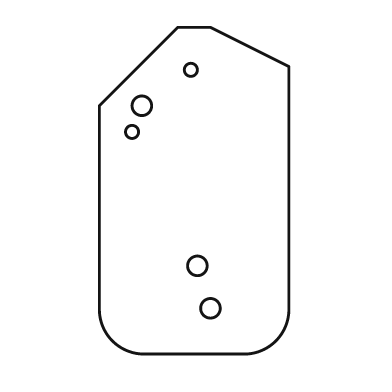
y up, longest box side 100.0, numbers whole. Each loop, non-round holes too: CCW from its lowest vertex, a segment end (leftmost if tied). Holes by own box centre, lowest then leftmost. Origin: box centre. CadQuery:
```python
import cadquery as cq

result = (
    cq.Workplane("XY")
    .moveTo(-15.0, -50.0)
    .lineTo(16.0, -50.0)
    .threePointArc((25.0, -46.0), (29.0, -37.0))
    .lineTo(29.0, 38.0)
    .lineTo(5.0, 50.0)
    .lineTo(-5.0, 50.0)
    .lineTo(-29.0, 26.0)
    .lineTo(-29.0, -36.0)
    .threePointArc((-25.0, -46.0), (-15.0, -50.0))
    .close()
    .moveTo(5.0, -36.0)
    .circle(3.0)
    .moveTo(1.0, -23.0)
    .circle(3.0)
    .moveTo(-19.0, 18.0)
    .circle(2.0)
    .moveTo(-16.0, 26.0)
    .circle(3.0)
    .moveTo(-1.0, 37.0)
    .circle(2.0)
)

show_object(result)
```